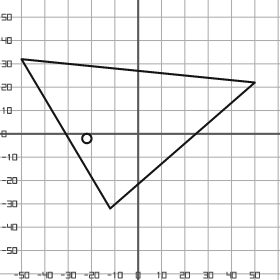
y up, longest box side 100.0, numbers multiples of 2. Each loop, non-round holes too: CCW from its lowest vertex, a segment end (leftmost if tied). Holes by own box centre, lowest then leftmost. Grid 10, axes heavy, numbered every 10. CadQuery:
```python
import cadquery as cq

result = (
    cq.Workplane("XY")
    .moveTo(-12.0, -32.0)
    .lineTo(50.0, 22.0)
    .lineTo(-50.0, 32.0)
    .close()
    .moveTo(-22.0, -2.0)
    .circle(2.0)
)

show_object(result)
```